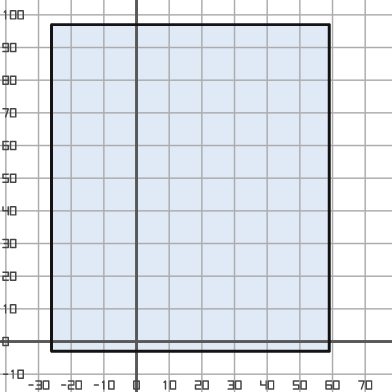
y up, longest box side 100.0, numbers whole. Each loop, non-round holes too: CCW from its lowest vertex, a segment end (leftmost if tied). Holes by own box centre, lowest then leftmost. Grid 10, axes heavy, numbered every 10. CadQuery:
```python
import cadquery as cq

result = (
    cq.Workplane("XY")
    .moveTo(-26.0, -3.0)
    .lineTo(59.0, -3.0)
    .lineTo(59.0, 97.0)
    .lineTo(-26.0, 97.0)
    .close()
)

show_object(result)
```